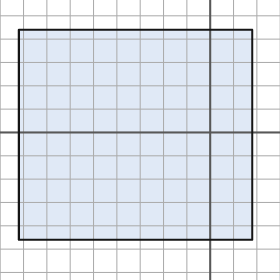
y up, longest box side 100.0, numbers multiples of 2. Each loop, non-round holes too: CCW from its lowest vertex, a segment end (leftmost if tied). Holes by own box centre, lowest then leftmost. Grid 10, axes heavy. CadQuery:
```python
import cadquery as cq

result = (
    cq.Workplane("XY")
    .moveTo(-82.0, -46.0)
    .lineTo(18.0, -46.0)
    .lineTo(18.0, 44.0)
    .lineTo(-82.0, 44.0)
    .close()
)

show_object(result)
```